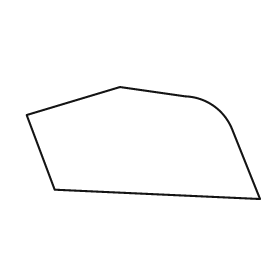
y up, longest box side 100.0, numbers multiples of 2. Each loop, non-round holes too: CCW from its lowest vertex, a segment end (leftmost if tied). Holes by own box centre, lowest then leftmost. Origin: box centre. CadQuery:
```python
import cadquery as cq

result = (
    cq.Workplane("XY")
    .moveTo(50.0, -24.0)
    .lineTo(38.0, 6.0)
    .threePointArc((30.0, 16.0), (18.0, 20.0))
    .lineTo(-10.0, 24.0)
    .lineTo(-50.0, 12.0)
    .lineTo(-38.0, -20.0)
    .close()
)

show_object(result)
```